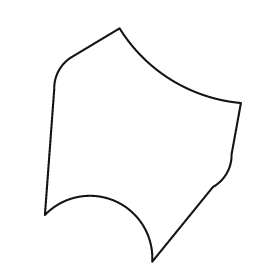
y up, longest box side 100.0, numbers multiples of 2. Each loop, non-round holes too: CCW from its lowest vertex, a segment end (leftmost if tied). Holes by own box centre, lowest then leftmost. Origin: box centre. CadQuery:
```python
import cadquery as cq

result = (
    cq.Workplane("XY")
    .moveTo(4.0, -50.0)
    .lineTo(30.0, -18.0)
    .threePointArc((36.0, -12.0), (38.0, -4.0))
    .lineTo(42.0, 18.0)
    .threePointArc((12.0, 28.0), (-10.0, 50.0))
    .lineTo(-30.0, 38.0)
    .threePointArc((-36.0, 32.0), (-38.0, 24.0))
    .lineTo(-42.0, -30.0)
    .threePointArc((-12.0, -24.0), (4.0, -50.0))
    .close()
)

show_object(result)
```